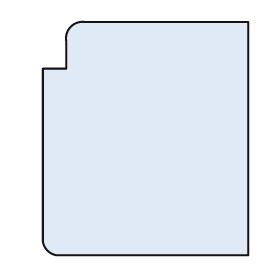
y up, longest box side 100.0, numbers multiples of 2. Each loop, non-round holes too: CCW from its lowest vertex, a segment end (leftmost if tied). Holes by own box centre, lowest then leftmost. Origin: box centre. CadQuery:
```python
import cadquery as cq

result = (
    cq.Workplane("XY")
    .moveTo(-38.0, -50.0)
    .lineTo(44.0, -50.0)
    .lineTo(44.0, 50.0)
    .lineTo(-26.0, 50.0)
    .threePointArc((-32.0, 48.0), (-34.0, 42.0))
    .lineTo(-34.0, 30.0)
    .lineTo(-44.0, 30.0)
    .lineTo(-44.0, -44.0)
    .threePointArc((-42.0, -48.0), (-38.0, -50.0))
    .close()
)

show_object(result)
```